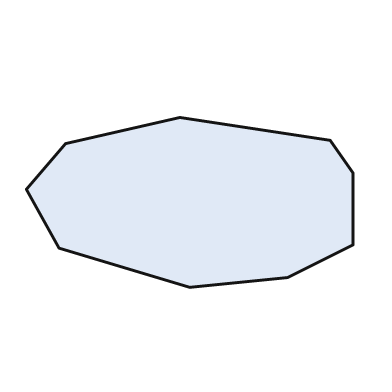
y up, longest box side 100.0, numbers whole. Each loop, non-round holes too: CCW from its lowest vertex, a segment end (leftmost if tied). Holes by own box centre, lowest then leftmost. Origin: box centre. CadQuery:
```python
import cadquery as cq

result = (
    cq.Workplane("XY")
    .moveTo(0.0, -26.0)
    .lineTo(30.0, -23.0)
    .lineTo(50.0, -13.0)
    .lineTo(50.0, 9.0)
    .lineTo(43.0, 19.0)
    .lineTo(-3.0, 26.0)
    .lineTo(-38.0, 18.0)
    .lineTo(-50.0, 4.0)
    .lineTo(-40.0, -14.0)
    .close()
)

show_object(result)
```